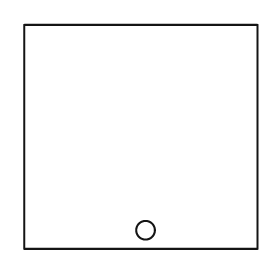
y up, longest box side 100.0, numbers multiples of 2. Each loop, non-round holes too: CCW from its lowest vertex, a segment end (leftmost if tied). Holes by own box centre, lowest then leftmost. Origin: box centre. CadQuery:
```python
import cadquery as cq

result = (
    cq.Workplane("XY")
    .moveTo(-50.0, -48.0)
    .lineTo(50.0, -48.0)
    .lineTo(50.0, 48.0)
    .lineTo(-50.0, 48.0)
    .close()
    .moveTo(2.0, -40.0)
    .circle(4.0)
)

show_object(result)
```